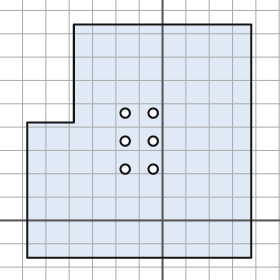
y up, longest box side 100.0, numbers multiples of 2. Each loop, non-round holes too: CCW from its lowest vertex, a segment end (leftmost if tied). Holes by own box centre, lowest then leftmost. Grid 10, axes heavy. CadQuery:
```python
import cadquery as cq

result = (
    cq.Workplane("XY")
    .moveTo(-58.0, -16.0)
    .lineTo(38.0, -16.0)
    .lineTo(38.0, 84.0)
    .lineTo(-38.0, 84.0)
    .lineTo(-38.0, 42.0)
    .lineTo(-58.0, 42.0)
    .close()
    .moveTo(-16.0, 22.0)
    .circle(2.0)
    .moveTo(-4.0, 22.0)
    .circle(2.0)
    .moveTo(-16.0, 34.0)
    .circle(2.0)
    .moveTo(-4.0, 34.0)
    .circle(2.0)
    .moveTo(-16.0, 46.0)
    .circle(2.0)
    .moveTo(-4.0, 46.0)
    .circle(2.0)
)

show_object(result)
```